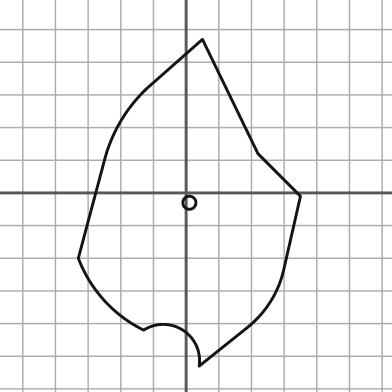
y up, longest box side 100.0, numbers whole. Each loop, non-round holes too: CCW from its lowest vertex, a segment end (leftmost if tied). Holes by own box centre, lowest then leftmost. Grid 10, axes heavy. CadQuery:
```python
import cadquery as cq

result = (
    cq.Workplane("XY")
    .moveTo(4.0, -53.0)
    .lineTo(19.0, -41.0)
    .threePointArc((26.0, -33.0), (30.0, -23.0))
    .lineTo(35.0, -1.0)
    .lineTo(22.0, 12.0)
    .lineTo(5.0, 47.0)
    .lineTo(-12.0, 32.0)
    .threePointArc((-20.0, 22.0), (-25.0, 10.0))
    .lineTo(-33.0, -20.0)
    .threePointArc((-25.0, -33.0), (-13.0, -42.0))
    .threePointArc((-1.0, -42.0), (4.0, -53.0))
    .close()
    .moveTo(1.0, -3.0)
    .circle(2.0)
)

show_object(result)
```